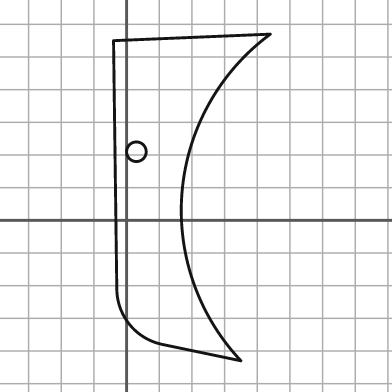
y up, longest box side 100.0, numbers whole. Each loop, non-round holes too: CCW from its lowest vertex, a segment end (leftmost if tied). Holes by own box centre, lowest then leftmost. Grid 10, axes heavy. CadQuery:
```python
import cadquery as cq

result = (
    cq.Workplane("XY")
    .moveTo(35.0, -43.0)
    .threePointArc((17.0, 9.0), (44.0, 57.0))
    .lineTo(-4.0, 55.0)
    .lineTo(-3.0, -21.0)
    .threePointArc((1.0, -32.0), (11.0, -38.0))
    .close()
    .moveTo(3.0, 21.0)
    .circle(3.0)
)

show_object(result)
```